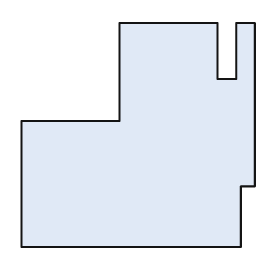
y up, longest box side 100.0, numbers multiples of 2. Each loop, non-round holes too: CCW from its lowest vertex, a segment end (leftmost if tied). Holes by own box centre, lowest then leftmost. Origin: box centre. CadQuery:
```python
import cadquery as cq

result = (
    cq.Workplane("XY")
    .moveTo(-50.0, -48.0)
    .lineTo(44.0, -48.0)
    .lineTo(44.0, -22.0)
    .lineTo(50.0, -22.0)
    .lineTo(50.0, 48.0)
    .lineTo(42.0, 48.0)
    .lineTo(42.0, 24.0)
    .lineTo(34.0, 24.0)
    .lineTo(34.0, 48.0)
    .lineTo(-8.0, 48.0)
    .lineTo(-8.0, 6.0)
    .lineTo(-50.0, 6.0)
    .close()
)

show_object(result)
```